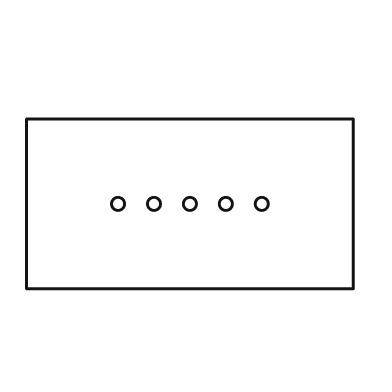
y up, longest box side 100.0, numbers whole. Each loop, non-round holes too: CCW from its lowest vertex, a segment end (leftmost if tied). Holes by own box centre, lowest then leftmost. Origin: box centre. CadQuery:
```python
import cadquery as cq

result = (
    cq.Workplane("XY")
    .moveTo(-50.0, -26.0)
    .lineTo(50.0, -26.0)
    .lineTo(50.0, 26.0)
    .lineTo(-50.0, 26.0)
    .close()
    .moveTo(-22.0, 0.0)
    .circle(2.0)
    .moveTo(-11.0, 0.0)
    .circle(2.0)
    .moveTo(0.0, 0.0)
    .circle(2.0)
    .moveTo(11.0, 0.0)
    .circle(2.0)
    .moveTo(22.0, 0.0)
    .circle(2.0)
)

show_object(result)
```